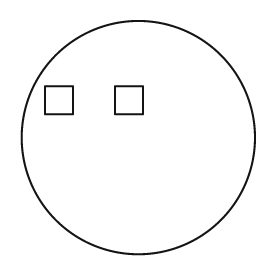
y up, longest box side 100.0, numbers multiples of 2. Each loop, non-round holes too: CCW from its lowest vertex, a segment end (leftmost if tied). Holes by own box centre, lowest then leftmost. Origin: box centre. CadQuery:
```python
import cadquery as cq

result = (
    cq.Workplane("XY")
    .moveTo(0.0, 0.0)
    .circle(50.0)
    .moveTo(-40.0, 10.0)
    .lineTo(-28.0, 10.0)
    .lineTo(-28.0, 22.0)
    .lineTo(-40.0, 22.0)
    .close()
    .moveTo(-10.0, 10.0)
    .lineTo(2.0, 10.0)
    .lineTo(2.0, 22.0)
    .lineTo(-10.0, 22.0)
    .close()
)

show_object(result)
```